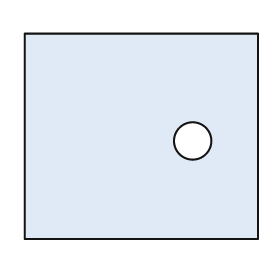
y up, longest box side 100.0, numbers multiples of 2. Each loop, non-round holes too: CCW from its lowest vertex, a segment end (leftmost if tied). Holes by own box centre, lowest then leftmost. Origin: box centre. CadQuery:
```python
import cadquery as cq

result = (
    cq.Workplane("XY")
    .moveTo(-50.0, -44.0)
    .lineTo(50.0, -44.0)
    .lineTo(50.0, 44.0)
    .lineTo(-50.0, 44.0)
    .close()
    .moveTo(22.0, -2.0)
    .circle(8.0)
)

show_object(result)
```